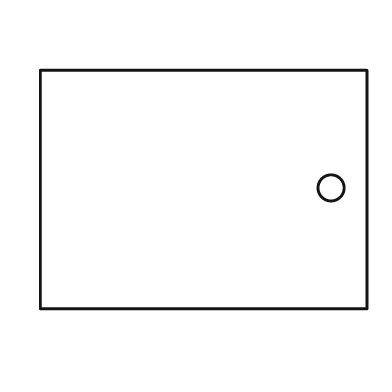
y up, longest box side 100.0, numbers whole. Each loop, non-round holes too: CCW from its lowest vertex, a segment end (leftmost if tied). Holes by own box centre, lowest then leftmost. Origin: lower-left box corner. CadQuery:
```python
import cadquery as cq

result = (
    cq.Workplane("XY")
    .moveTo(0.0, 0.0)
    .lineTo(100.0, 0.0)
    .lineTo(100.0, 73.0)
    .lineTo(0.0, 73.0)
    .close()
    .moveTo(89.0, 37.0)
    .circle(4.0)
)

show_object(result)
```